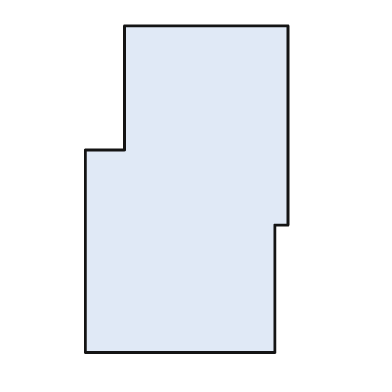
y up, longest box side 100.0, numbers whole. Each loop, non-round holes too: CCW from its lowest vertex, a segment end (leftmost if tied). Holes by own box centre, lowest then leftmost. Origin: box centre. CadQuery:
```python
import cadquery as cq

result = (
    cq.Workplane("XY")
    .moveTo(-31.0, -50.0)
    .lineTo(27.0, -50.0)
    .lineTo(27.0, -11.0)
    .lineTo(31.0, -11.0)
    .lineTo(31.0, 50.0)
    .lineTo(-19.0, 50.0)
    .lineTo(-19.0, 12.0)
    .lineTo(-31.0, 12.0)
    .close()
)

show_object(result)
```